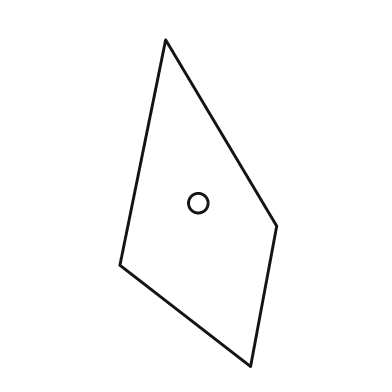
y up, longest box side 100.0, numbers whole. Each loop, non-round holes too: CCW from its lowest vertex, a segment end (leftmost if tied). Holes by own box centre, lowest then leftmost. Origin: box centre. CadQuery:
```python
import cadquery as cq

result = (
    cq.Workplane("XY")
    .moveTo(16.0, -50.0)
    .lineTo(24.0, -7.0)
    .lineTo(-10.0, 50.0)
    .lineTo(-24.0, -19.0)
    .close()
    .moveTo(0.0, 0.0)
    .circle(3.0)
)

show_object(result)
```